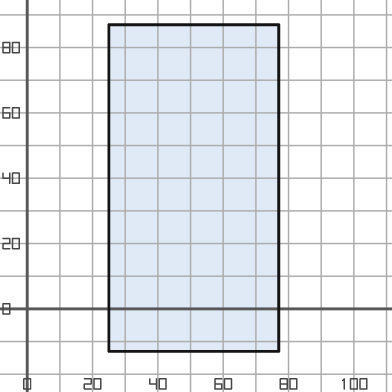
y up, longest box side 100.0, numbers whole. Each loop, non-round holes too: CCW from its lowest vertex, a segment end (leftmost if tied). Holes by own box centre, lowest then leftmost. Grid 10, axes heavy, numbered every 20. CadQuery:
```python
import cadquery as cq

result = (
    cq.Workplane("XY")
    .moveTo(25.0, -13.0)
    .lineTo(77.0, -13.0)
    .lineTo(77.0, 87.0)
    .lineTo(25.0, 87.0)
    .close()
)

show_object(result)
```